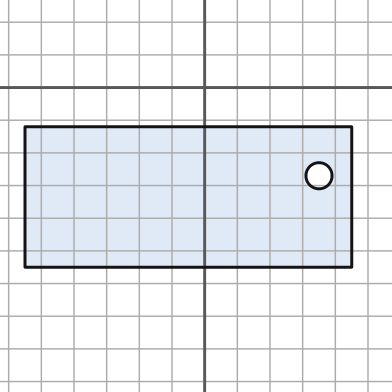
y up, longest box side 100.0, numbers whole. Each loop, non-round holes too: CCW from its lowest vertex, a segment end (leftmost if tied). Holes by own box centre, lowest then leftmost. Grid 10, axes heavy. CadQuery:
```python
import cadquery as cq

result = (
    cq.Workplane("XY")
    .moveTo(-55.0, -55.0)
    .lineTo(45.0, -55.0)
    .lineTo(45.0, -12.0)
    .lineTo(-55.0, -12.0)
    .close()
    .moveTo(35.0, -27.0)
    .circle(4.0)
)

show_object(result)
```